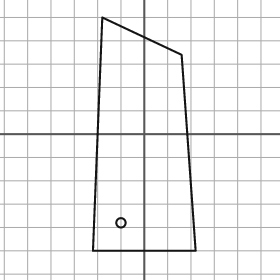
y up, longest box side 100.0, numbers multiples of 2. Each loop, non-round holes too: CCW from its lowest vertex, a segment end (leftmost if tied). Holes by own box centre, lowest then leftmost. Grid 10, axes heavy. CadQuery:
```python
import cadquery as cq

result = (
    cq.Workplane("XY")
    .moveTo(-22.0, -50.0)
    .lineTo(22.0, -50.0)
    .lineTo(16.0, 34.0)
    .lineTo(-18.0, 50.0)
    .close()
    .moveTo(-10.0, -38.0)
    .circle(2.0)
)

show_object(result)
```